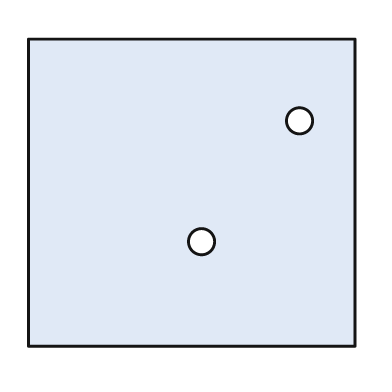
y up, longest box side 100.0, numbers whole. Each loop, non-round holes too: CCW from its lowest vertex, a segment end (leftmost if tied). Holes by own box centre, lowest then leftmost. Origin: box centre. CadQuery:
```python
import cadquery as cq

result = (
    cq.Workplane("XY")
    .moveTo(-50.0, -47.0)
    .lineTo(50.0, -47.0)
    .lineTo(50.0, 47.0)
    .lineTo(-50.0, 47.0)
    .close()
    .moveTo(3.0, -15.0)
    .circle(4.0)
    .moveTo(33.0, 22.0)
    .circle(4.0)
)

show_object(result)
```